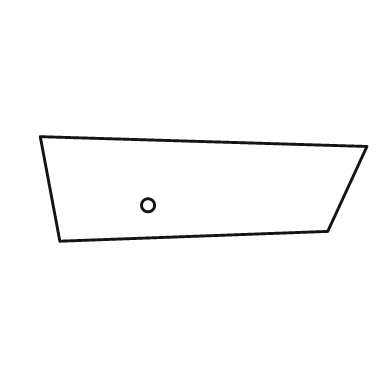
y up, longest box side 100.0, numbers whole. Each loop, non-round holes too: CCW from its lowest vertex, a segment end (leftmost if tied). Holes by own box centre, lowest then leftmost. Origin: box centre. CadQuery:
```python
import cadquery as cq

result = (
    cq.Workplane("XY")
    .moveTo(-44.0, -16.0)
    .lineTo(38.0, -13.0)
    .lineTo(50.0, 13.0)
    .lineTo(-50.0, 16.0)
    .close()
    .moveTo(-17.0, -5.0)
    .circle(2.0)
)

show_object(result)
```